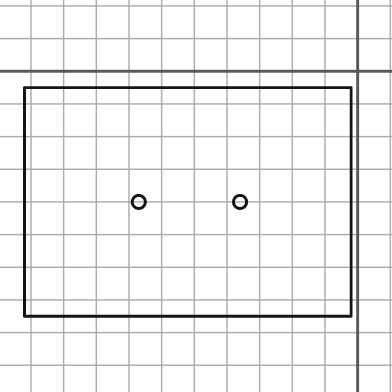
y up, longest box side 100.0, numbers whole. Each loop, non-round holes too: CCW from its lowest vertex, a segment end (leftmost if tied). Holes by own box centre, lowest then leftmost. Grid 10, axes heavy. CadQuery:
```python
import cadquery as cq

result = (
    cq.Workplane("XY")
    .moveTo(-102.0, -75.0)
    .lineTo(-2.0, -75.0)
    .lineTo(-2.0, -5.0)
    .lineTo(-102.0, -5.0)
    .close()
    .moveTo(-67.0, -40.0)
    .circle(2.0)
    .moveTo(-36.0, -40.0)
    .circle(2.0)
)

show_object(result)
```